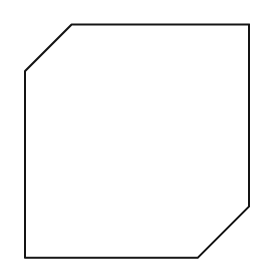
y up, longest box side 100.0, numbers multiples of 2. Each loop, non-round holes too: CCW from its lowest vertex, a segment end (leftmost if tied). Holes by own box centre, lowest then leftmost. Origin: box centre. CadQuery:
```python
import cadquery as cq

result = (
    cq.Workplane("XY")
    .moveTo(-48.0, -50.0)
    .lineTo(26.0, -50.0)
    .lineTo(48.0, -28.0)
    .lineTo(48.0, 50.0)
    .lineTo(-28.0, 50.0)
    .lineTo(-48.0, 30.0)
    .close()
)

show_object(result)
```